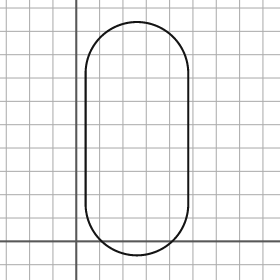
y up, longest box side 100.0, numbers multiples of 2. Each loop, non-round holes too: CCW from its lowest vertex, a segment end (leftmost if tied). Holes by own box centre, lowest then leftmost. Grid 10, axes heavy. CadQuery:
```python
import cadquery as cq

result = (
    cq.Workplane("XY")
    .moveTo(4.0, 16.0)
    .threePointArc((26.0, -6.0), (48.0, 16.0))
    .lineTo(48.0, 72.0)
    .threePointArc((26.0, 94.0), (4.0, 72.0))
    .close()
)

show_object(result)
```